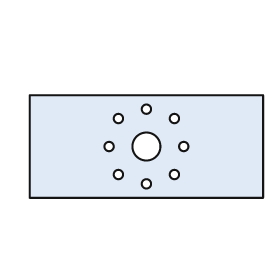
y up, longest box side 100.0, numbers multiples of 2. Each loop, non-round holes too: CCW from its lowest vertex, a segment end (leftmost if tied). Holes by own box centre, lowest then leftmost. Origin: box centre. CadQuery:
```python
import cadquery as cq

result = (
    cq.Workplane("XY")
    .moveTo(-50.0, -22.0)
    .lineTo(50.0, -22.0)
    .lineTo(50.0, 22.0)
    .lineTo(-50.0, 22.0)
    .close()
    .moveTo(0.0, -16.0)
    .circle(2.0)
    .moveTo(-12.0, -12.0)
    .circle(2.0)
    .moveTo(12.0, -12.0)
    .circle(2.0)
    .moveTo(-16.0, 0.0)
    .circle(2.0)
    .moveTo(0.0, 0.0)
    .circle(6.0)
    .moveTo(16.0, 0.0)
    .circle(2.0)
    .moveTo(-12.0, 12.0)
    .circle(2.0)
    .moveTo(12.0, 12.0)
    .circle(2.0)
    .moveTo(0.0, 16.0)
    .circle(2.0)
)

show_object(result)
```